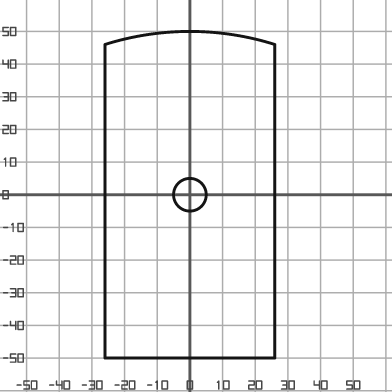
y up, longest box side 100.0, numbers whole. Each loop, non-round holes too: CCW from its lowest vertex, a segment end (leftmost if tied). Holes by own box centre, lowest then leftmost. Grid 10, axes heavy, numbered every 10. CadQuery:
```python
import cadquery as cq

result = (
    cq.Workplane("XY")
    .moveTo(-26.0, -50.0)
    .lineTo(26.0, -50.0)
    .lineTo(26.0, 46.0)
    .threePointArc((0.0, 50.0), (-26.0, 46.0))
    .close()
    .moveTo(0.0, 0.0)
    .circle(5.0)
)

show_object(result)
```